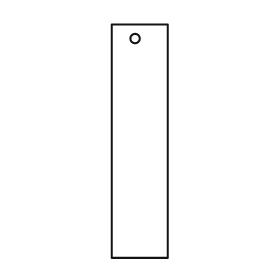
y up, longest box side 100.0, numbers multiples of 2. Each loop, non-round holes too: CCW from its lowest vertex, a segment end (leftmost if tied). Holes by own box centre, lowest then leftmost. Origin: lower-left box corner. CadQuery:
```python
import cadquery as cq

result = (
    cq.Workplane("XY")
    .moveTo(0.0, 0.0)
    .lineTo(24.0, 0.0)
    .lineTo(24.0, 100.0)
    .lineTo(0.0, 100.0)
    .close()
    .moveTo(10.0, 94.0)
    .circle(2.0)
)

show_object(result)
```